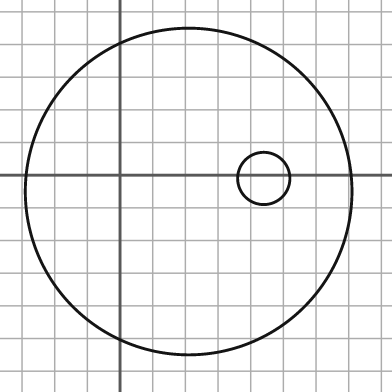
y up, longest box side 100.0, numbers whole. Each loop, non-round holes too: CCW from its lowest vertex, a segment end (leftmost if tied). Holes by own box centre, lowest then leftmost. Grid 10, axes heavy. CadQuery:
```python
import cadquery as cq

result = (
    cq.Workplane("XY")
    .moveTo(21.0, -5.0)
    .circle(50.0)
    .moveTo(44.0, -1.0)
    .circle(8.0)
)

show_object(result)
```